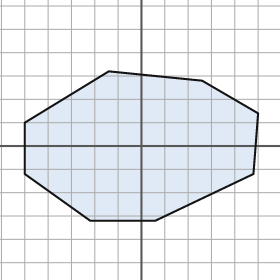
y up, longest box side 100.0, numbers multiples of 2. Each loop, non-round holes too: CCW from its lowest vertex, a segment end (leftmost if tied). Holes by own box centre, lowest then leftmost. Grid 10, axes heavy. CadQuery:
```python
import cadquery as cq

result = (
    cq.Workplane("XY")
    .moveTo(-22.0, -32.0)
    .lineTo(6.0, -32.0)
    .lineTo(48.0, -12.0)
    .lineTo(50.0, 14.0)
    .lineTo(26.0, 28.0)
    .lineTo(-14.0, 32.0)
    .lineTo(-50.0, 10.0)
    .lineTo(-50.0, -12.0)
    .close()
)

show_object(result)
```